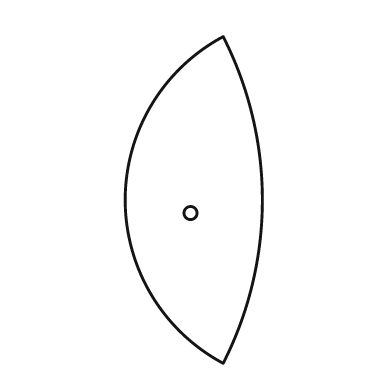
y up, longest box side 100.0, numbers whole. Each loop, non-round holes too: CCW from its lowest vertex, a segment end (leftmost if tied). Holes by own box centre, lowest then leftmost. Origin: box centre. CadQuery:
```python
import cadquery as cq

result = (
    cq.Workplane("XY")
    .moveTo(9.0, -50.0)
    .threePointArc((21.0, 0.0), (9.0, 50.0))
    .threePointArc((-21.0, 0.0), (9.0, -50.0))
    .close()
    .moveTo(-1.0, -4.0)
    .circle(2.0)
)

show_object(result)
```